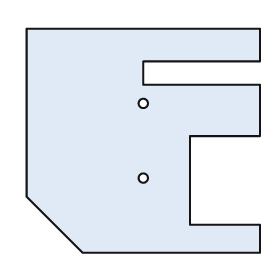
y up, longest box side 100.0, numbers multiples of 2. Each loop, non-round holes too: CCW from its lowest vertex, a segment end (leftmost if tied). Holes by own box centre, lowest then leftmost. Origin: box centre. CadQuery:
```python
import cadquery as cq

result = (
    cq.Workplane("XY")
    .moveTo(-26.0, -48.0)
    .lineTo(50.0, -48.0)
    .lineTo(50.0, -36.0)
    .lineTo(20.0, -36.0)
    .lineTo(20.0, 2.0)
    .lineTo(50.0, 2.0)
    .lineTo(50.0, 24.0)
    .lineTo(0.0, 24.0)
    .lineTo(0.0, 34.0)
    .lineTo(50.0, 34.0)
    .lineTo(50.0, 48.0)
    .lineTo(-50.0, 48.0)
    .lineTo(-50.0, -24.0)
    .close()
    .moveTo(0.0, -16.0)
    .circle(2.0)
    .moveTo(0.0, 16.0)
    .circle(2.0)
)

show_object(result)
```